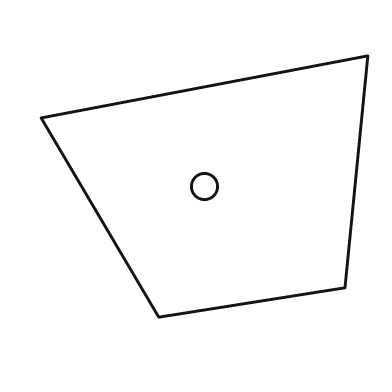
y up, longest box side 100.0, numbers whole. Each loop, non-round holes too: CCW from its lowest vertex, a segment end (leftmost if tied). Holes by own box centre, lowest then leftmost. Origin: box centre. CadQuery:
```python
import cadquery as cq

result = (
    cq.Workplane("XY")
    .moveTo(-14.0, -40.0)
    .lineTo(43.0, -31.0)
    .lineTo(50.0, 40.0)
    .lineTo(-50.0, 21.0)
    .close()
    .moveTo(0.0, 0.0)
    .circle(4.0)
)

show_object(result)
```